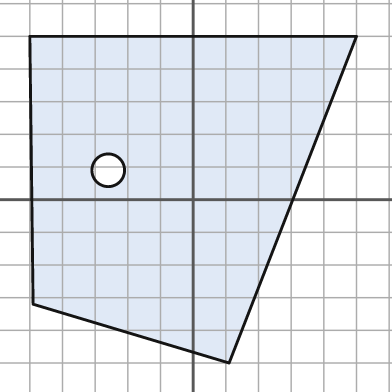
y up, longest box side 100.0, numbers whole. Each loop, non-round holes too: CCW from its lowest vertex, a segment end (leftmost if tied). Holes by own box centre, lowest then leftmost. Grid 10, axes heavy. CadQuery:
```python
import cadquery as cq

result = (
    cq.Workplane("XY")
    .moveTo(11.0, -50.0)
    .lineTo(50.0, 50.0)
    .lineTo(-50.0, 50.0)
    .lineTo(-49.0, -32.0)
    .close()
    .moveTo(-26.0, 9.0)
    .circle(5.0)
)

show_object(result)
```